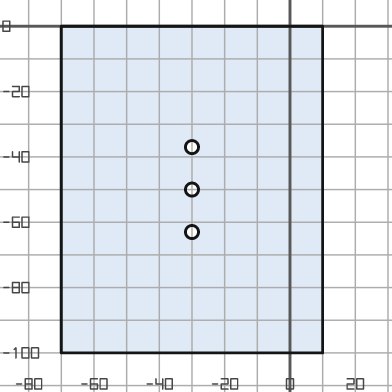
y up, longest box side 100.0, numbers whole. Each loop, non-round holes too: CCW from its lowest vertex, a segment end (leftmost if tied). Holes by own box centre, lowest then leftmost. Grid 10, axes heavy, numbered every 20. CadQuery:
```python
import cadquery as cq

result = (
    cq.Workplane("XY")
    .moveTo(-70.0, -100.0)
    .lineTo(10.0, -100.0)
    .lineTo(10.0, 0.0)
    .lineTo(-70.0, 0.0)
    .close()
    .moveTo(-30.0, -63.0)
    .circle(2.0)
    .moveTo(-30.0, -50.0)
    .circle(2.0)
    .moveTo(-30.0, -37.0)
    .circle(2.0)
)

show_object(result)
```